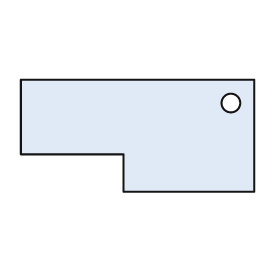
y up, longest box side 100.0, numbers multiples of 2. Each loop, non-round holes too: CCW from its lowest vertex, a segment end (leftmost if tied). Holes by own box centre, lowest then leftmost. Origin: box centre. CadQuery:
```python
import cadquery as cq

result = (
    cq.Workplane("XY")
    .moveTo(-6.0, -24.0)
    .lineTo(50.0, -24.0)
    .lineTo(50.0, 24.0)
    .lineTo(-50.0, 24.0)
    .lineTo(-50.0, -8.0)
    .lineTo(-6.0, -8.0)
    .close()
    .moveTo(40.0, 14.0)
    .circle(4.0)
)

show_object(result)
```